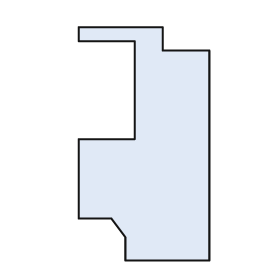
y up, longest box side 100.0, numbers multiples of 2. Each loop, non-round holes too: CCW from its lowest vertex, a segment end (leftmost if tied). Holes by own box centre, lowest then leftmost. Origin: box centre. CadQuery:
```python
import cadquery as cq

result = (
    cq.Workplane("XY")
    .moveTo(-8.0, -50.0)
    .lineTo(28.0, -50.0)
    .lineTo(28.0, 40.0)
    .lineTo(8.0, 40.0)
    .lineTo(8.0, 50.0)
    .lineTo(-28.0, 50.0)
    .lineTo(-28.0, 44.0)
    .lineTo(-4.0, 44.0)
    .lineTo(-4.0, 2.0)
    .lineTo(-28.0, 2.0)
    .lineTo(-28.0, -32.0)
    .lineTo(-14.0, -32.0)
    .lineTo(-8.0, -40.0)
    .close()
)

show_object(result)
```